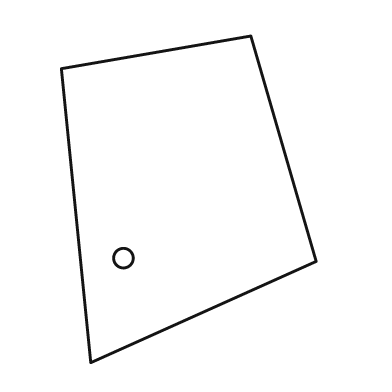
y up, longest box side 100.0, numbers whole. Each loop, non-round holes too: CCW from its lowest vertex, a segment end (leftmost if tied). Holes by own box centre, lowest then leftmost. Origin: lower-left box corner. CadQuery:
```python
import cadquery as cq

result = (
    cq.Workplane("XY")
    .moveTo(9.0, 0.0)
    .lineTo(78.0, 31.0)
    .lineTo(58.0, 100.0)
    .lineTo(0.0, 90.0)
    .close()
    .moveTo(19.0, 32.0)
    .circle(3.0)
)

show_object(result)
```